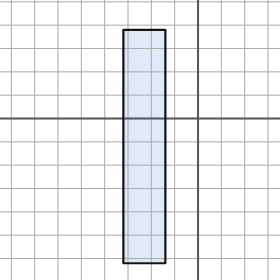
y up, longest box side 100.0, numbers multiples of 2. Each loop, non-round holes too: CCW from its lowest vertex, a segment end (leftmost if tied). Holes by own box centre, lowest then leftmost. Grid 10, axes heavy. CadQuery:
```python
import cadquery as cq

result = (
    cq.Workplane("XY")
    .moveTo(-32.0, -62.0)
    .lineTo(-14.0, -62.0)
    .lineTo(-14.0, 38.0)
    .lineTo(-32.0, 38.0)
    .close()
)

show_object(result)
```